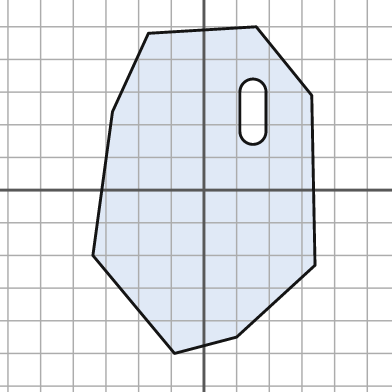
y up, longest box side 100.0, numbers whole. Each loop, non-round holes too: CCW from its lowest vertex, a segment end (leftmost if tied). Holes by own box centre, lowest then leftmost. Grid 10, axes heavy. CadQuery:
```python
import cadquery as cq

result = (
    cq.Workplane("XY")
    .moveTo(-9.0, -50.0)
    .lineTo(10.0, -45.0)
    .lineTo(34.0, -23.0)
    .lineTo(33.0, 29.0)
    .lineTo(16.0, 50.0)
    .lineTo(-17.0, 48.0)
    .lineTo(-28.0, 24.0)
    .lineTo(-34.0, -20.0)
    .close()
    .moveTo(11.0, 18.0)
    .threePointArc((15.0, 14.0), (19.0, 18.0))
    .lineTo(19.0, 30.0)
    .threePointArc((15.0, 34.0), (11.0, 30.0))
    .close()
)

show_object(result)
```